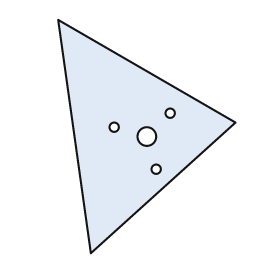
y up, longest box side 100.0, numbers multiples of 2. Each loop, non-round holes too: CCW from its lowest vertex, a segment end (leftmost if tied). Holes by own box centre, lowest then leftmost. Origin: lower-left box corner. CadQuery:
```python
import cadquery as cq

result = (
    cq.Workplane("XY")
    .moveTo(14.0, 0.0)
    .lineTo(76.0, 56.0)
    .lineTo(0.0, 100.0)
    .close()
    .moveTo(42.0, 36.0)
    .circle(2.0)
    .moveTo(38.0, 50.0)
    .circle(4.0)
    .moveTo(24.0, 54.0)
    .circle(2.0)
    .moveTo(48.0, 60.0)
    .circle(2.0)
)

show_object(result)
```